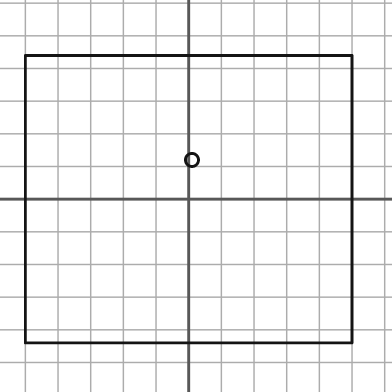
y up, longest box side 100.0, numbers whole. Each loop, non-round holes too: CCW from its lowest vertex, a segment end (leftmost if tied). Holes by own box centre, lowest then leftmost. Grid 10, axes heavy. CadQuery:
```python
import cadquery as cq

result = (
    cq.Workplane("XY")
    .moveTo(-50.0, -44.0)
    .lineTo(50.0, -44.0)
    .lineTo(50.0, 44.0)
    .lineTo(-50.0, 44.0)
    .close()
    .moveTo(1.0, 12.0)
    .circle(2.0)
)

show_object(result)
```